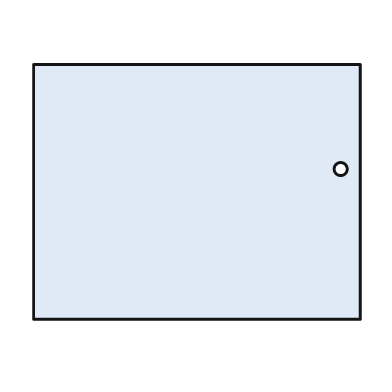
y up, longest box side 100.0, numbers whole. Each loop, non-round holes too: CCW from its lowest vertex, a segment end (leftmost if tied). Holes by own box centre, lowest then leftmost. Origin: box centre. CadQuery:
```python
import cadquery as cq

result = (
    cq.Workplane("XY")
    .moveTo(-50.0, -39.0)
    .lineTo(50.0, -39.0)
    .lineTo(50.0, 39.0)
    .lineTo(-50.0, 39.0)
    .close()
    .moveTo(44.0, 7.0)
    .circle(2.0)
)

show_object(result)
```